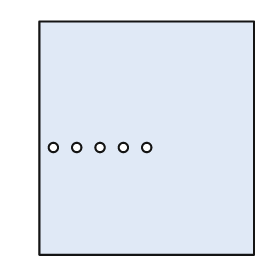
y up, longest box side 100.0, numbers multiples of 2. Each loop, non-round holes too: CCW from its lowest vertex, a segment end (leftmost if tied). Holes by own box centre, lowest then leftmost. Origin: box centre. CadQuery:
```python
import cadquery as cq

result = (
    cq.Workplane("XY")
    .moveTo(-46.0, -50.0)
    .lineTo(46.0, -50.0)
    .lineTo(46.0, 50.0)
    .lineTo(-46.0, 50.0)
    .close()
    .moveTo(-40.0, -4.0)
    .circle(2.0)
    .moveTo(-30.0, -4.0)
    .circle(2.0)
    .moveTo(-20.0, -4.0)
    .circle(2.0)
    .moveTo(-10.0, -4.0)
    .circle(2.0)
    .moveTo(0.0, -4.0)
    .circle(2.0)
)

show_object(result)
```